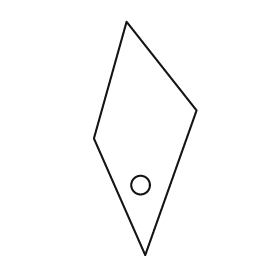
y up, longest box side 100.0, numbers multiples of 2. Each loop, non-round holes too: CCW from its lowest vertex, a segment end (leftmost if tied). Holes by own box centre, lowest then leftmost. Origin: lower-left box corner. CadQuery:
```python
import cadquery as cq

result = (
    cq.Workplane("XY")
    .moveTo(22.0, 0.0)
    .lineTo(44.0, 62.0)
    .lineTo(14.0, 100.0)
    .lineTo(0.0, 50.0)
    .close()
    .moveTo(20.0, 30.0)
    .circle(4.0)
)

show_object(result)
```